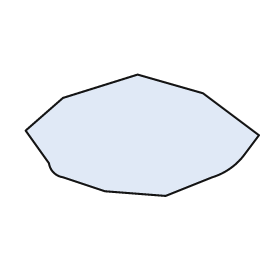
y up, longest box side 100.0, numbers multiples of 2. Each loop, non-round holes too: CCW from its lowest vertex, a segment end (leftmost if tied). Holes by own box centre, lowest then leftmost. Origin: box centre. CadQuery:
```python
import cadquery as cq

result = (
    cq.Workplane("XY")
    .moveTo(10.0, -26.0)
    .lineTo(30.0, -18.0)
    .threePointArc((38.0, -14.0), (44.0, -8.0))
    .lineTo(50.0, 0.0)
    .lineTo(26.0, 18.0)
    .lineTo(-2.0, 26.0)
    .lineTo(-34.0, 16.0)
    .lineTo(-50.0, 2.0)
    .lineTo(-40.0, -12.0)
    .threePointArc((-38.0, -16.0), (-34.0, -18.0))
    .lineTo(-16.0, -24.0)
    .close()
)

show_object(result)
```